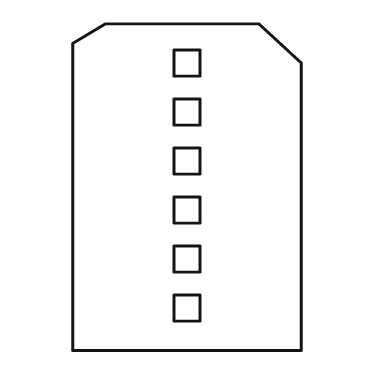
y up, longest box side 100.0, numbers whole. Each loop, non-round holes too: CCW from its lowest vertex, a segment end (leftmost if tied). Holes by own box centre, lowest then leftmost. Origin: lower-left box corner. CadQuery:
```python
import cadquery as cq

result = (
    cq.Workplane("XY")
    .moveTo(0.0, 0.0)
    .lineTo(70.0, 0.0)
    .lineTo(70.0, 88.0)
    .lineTo(57.0, 100.0)
    .lineTo(10.0, 100.0)
    .lineTo(0.0, 94.0)
    .close()
    .moveTo(31.0, 9.0)
    .lineTo(39.0, 9.0)
    .lineTo(39.0, 17.0)
    .lineTo(31.0, 17.0)
    .close()
    .moveTo(31.0, 24.0)
    .lineTo(39.0, 24.0)
    .lineTo(39.0, 32.0)
    .lineTo(31.0, 32.0)
    .close()
    .moveTo(31.0, 39.0)
    .lineTo(39.0, 39.0)
    .lineTo(39.0, 47.0)
    .lineTo(31.0, 47.0)
    .close()
    .moveTo(31.0, 54.0)
    .lineTo(39.0, 54.0)
    .lineTo(39.0, 62.0)
    .lineTo(31.0, 62.0)
    .close()
    .moveTo(31.0, 69.0)
    .lineTo(39.0, 69.0)
    .lineTo(39.0, 77.0)
    .lineTo(31.0, 77.0)
    .close()
    .moveTo(31.0, 84.0)
    .lineTo(39.0, 84.0)
    .lineTo(39.0, 92.0)
    .lineTo(31.0, 92.0)
    .close()
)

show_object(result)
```